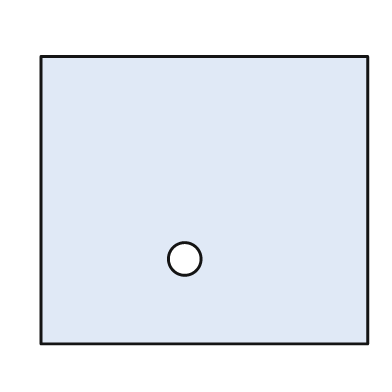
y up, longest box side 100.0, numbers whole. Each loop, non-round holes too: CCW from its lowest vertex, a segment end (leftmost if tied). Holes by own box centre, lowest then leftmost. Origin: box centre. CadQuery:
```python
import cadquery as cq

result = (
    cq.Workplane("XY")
    .moveTo(-50.0, -44.0)
    .lineTo(50.0, -44.0)
    .lineTo(50.0, 44.0)
    .lineTo(-50.0, 44.0)
    .close()
    .moveTo(-6.0, -18.0)
    .circle(5.0)
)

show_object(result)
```